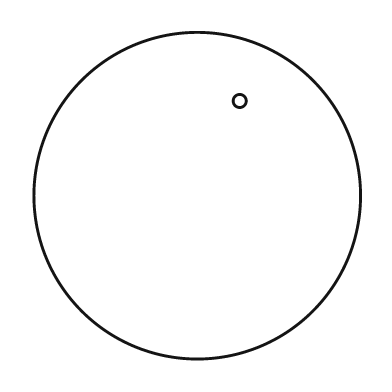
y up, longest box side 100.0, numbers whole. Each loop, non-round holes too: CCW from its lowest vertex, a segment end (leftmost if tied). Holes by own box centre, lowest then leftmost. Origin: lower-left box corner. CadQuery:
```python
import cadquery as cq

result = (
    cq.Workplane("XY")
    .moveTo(50.0, 50.0)
    .circle(50.0)
    .moveTo(63.0, 79.0)
    .circle(2.0)
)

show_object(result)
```